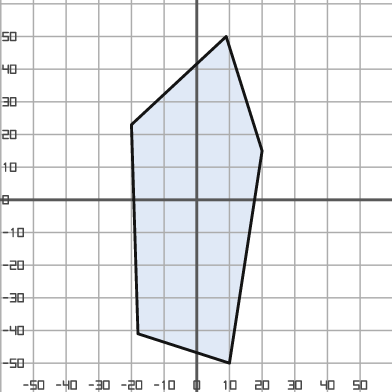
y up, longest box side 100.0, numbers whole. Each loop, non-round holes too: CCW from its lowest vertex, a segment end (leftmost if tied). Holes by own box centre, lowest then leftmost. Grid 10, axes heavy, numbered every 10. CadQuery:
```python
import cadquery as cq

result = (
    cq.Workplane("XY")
    .moveTo(10.0, -50.0)
    .lineTo(20.0, 15.0)
    .lineTo(9.0, 50.0)
    .lineTo(-20.0, 23.0)
    .lineTo(-18.0, -41.0)
    .close()
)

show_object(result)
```